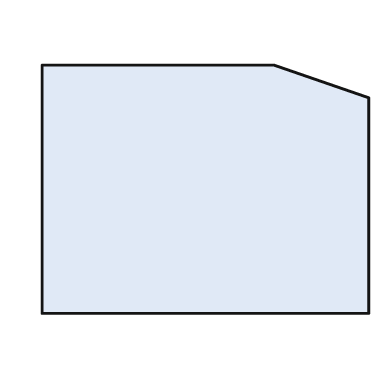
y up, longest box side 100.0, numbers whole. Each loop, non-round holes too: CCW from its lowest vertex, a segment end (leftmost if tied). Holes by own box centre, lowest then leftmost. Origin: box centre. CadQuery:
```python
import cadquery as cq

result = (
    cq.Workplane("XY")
    .moveTo(-50.0, -38.0)
    .lineTo(50.0, -38.0)
    .lineTo(50.0, 28.0)
    .lineTo(21.0, 38.0)
    .lineTo(-50.0, 38.0)
    .close()
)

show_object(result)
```